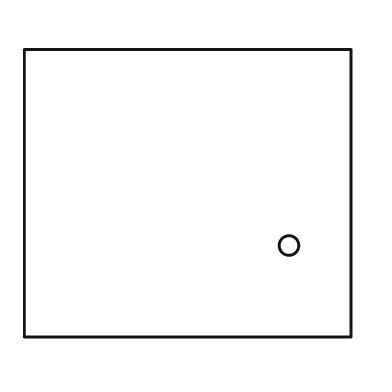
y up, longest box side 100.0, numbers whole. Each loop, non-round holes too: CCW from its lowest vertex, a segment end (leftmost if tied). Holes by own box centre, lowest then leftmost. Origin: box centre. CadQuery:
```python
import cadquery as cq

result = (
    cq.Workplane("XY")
    .moveTo(-50.0, -44.0)
    .lineTo(50.0, -44.0)
    .lineTo(50.0, 44.0)
    .lineTo(-50.0, 44.0)
    .close()
    .moveTo(31.0, -16.0)
    .circle(3.0)
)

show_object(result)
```